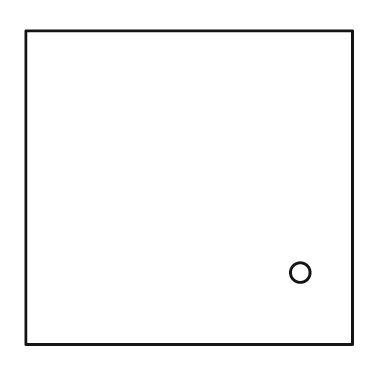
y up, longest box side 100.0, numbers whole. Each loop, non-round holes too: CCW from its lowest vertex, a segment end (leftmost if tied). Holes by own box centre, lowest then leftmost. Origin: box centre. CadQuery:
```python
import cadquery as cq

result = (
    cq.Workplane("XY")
    .moveTo(-50.0, -48.0)
    .lineTo(50.0, -48.0)
    .lineTo(50.0, 48.0)
    .lineTo(-50.0, 48.0)
    .close()
    .moveTo(34.0, -26.0)
    .circle(3.0)
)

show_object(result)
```